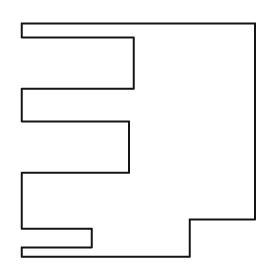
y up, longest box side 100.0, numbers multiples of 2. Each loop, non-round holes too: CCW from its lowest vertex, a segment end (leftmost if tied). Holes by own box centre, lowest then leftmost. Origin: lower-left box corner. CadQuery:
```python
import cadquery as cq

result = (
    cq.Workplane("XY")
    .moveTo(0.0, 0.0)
    .lineTo(72.0, 0.0)
    .lineTo(72.0, 16.0)
    .lineTo(100.0, 16.0)
    .lineTo(100.0, 100.0)
    .lineTo(0.0, 100.0)
    .lineTo(0.0, 94.0)
    .lineTo(48.0, 94.0)
    .lineTo(48.0, 72.0)
    .lineTo(0.0, 72.0)
    .lineTo(0.0, 58.0)
    .lineTo(46.0, 58.0)
    .lineTo(46.0, 36.0)
    .lineTo(0.0, 36.0)
    .lineTo(0.0, 12.0)
    .lineTo(30.0, 12.0)
    .lineTo(30.0, 4.0)
    .lineTo(0.0, 4.0)
    .close()
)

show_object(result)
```